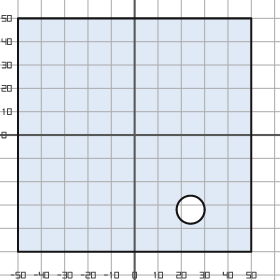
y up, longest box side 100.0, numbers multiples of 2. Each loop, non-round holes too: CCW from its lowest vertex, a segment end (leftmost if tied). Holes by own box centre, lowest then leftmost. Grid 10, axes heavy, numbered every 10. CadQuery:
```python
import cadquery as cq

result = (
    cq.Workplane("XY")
    .moveTo(-50.0, -50.0)
    .lineTo(50.0, -50.0)
    .lineTo(50.0, 50.0)
    .lineTo(-50.0, 50.0)
    .close()
    .moveTo(24.0, -32.0)
    .circle(6.0)
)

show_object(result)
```